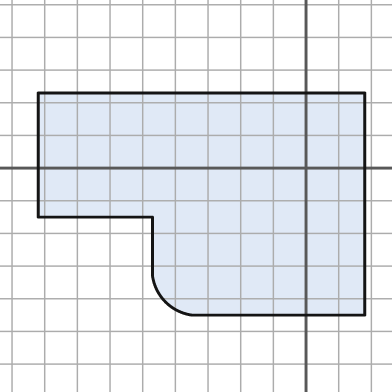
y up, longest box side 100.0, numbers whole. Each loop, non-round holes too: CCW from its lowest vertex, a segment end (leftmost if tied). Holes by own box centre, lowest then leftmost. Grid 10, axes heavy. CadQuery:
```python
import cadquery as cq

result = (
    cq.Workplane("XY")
    .moveTo(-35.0, -45.0)
    .lineTo(18.0, -45.0)
    .lineTo(18.0, 23.0)
    .lineTo(-82.0, 23.0)
    .lineTo(-82.0, -15.0)
    .lineTo(-47.0, -15.0)
    .lineTo(-47.0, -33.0)
    .threePointArc((-43.0, -41.0), (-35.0, -45.0))
    .close()
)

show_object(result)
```